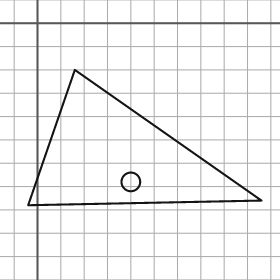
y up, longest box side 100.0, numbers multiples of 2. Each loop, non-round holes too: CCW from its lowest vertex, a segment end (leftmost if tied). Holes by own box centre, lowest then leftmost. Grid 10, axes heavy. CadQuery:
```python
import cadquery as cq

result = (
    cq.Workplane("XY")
    .moveTo(-4.0, -78.0)
    .lineTo(96.0, -76.0)
    .lineTo(16.0, -20.0)
    .close()
    .moveTo(40.0, -68.0)
    .circle(4.0)
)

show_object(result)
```